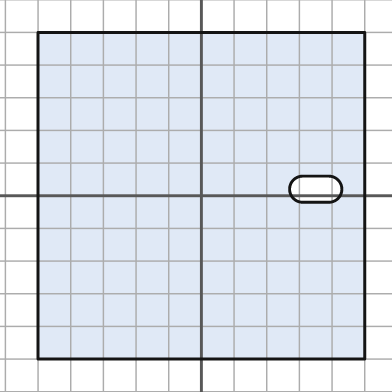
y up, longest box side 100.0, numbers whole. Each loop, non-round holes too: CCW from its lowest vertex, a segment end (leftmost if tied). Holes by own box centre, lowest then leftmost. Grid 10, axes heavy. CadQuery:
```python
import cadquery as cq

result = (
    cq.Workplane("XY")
    .moveTo(-50.0, -50.0)
    .lineTo(50.0, -50.0)
    .lineTo(50.0, 50.0)
    .lineTo(-50.0, 50.0)
    .close()
    .moveTo(31.0, -2.0)
    .lineTo(39.0, -2.0)
    .threePointArc((43.0, 2.0), (39.0, 6.0))
    .lineTo(31.0, 6.0)
    .threePointArc((27.0, 2.0), (31.0, -2.0))
    .close()
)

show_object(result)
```